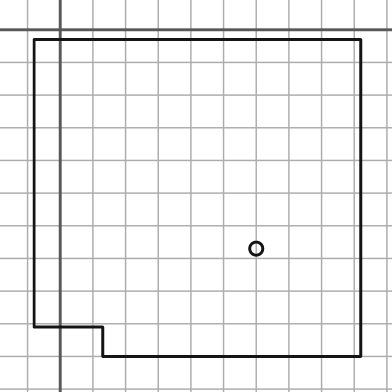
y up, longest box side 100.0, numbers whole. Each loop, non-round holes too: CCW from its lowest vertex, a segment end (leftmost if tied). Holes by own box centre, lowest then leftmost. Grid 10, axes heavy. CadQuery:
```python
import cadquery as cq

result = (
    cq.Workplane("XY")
    .moveTo(13.0, -100.0)
    .lineTo(92.0, -100.0)
    .lineTo(92.0, -3.0)
    .lineTo(-8.0, -3.0)
    .lineTo(-8.0, -91.0)
    .lineTo(13.0, -91.0)
    .close()
    .moveTo(60.0, -67.0)
    .circle(2.0)
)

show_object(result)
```